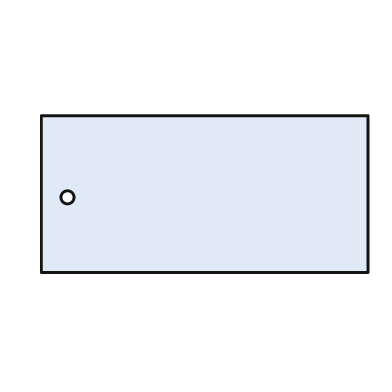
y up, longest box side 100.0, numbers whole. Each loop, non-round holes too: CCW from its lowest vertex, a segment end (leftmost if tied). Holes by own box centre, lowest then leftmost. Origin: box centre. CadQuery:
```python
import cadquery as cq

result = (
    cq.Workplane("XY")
    .moveTo(-50.0, -24.0)
    .lineTo(50.0, -24.0)
    .lineTo(50.0, 24.0)
    .lineTo(-50.0, 24.0)
    .close()
    .moveTo(-42.0, -1.0)
    .circle(2.0)
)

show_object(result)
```